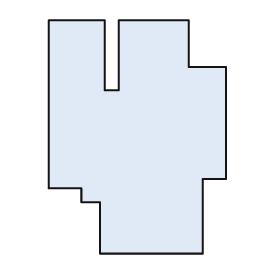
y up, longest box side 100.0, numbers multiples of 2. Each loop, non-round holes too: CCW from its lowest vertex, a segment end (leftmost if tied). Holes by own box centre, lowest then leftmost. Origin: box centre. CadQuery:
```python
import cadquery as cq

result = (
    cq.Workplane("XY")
    .moveTo(-16.0, -50.0)
    .lineTo(28.0, -50.0)
    .lineTo(28.0, -18.0)
    .lineTo(38.0, -18.0)
    .lineTo(38.0, 30.0)
    .lineTo(22.0, 30.0)
    .lineTo(22.0, 50.0)
    .lineTo(-8.0, 50.0)
    .lineTo(-8.0, 20.0)
    .lineTo(-14.0, 20.0)
    .lineTo(-14.0, 50.0)
    .lineTo(-38.0, 50.0)
    .lineTo(-38.0, -22.0)
    .lineTo(-24.0, -22.0)
    .lineTo(-24.0, -28.0)
    .lineTo(-16.0, -28.0)
    .close()
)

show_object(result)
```